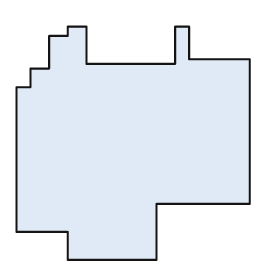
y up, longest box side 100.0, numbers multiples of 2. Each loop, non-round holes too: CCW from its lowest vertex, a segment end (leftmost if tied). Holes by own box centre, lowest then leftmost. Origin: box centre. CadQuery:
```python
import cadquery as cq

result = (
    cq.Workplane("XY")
    .moveTo(-28.0, -50.0)
    .lineTo(10.0, -50.0)
    .lineTo(10.0, -26.0)
    .lineTo(50.0, -26.0)
    .lineTo(50.0, 36.0)
    .lineTo(24.0, 36.0)
    .lineTo(24.0, 50.0)
    .lineTo(18.0, 50.0)
    .lineTo(18.0, 34.0)
    .lineTo(-20.0, 34.0)
    .lineTo(-20.0, 50.0)
    .lineTo(-28.0, 50.0)
    .lineTo(-28.0, 46.0)
    .lineTo(-36.0, 46.0)
    .lineTo(-36.0, 32.0)
    .lineTo(-44.0, 32.0)
    .lineTo(-44.0, 24.0)
    .lineTo(-50.0, 24.0)
    .lineTo(-50.0, -38.0)
    .lineTo(-28.0, -38.0)
    .close()
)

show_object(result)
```